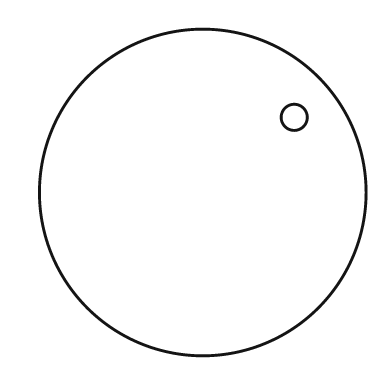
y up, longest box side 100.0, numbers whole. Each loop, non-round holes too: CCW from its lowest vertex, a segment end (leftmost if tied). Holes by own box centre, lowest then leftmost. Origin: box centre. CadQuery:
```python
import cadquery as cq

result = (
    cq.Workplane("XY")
    .moveTo(0.0, 0.0)
    .circle(50.0)
    .moveTo(28.0, 23.0)
    .circle(4.0)
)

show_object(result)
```